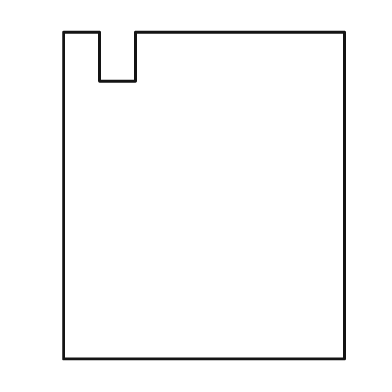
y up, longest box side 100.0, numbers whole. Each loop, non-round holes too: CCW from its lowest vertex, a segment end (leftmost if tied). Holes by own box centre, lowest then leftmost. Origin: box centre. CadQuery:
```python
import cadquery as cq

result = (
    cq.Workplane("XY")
    .moveTo(-43.0, -50.0)
    .lineTo(43.0, -50.0)
    .lineTo(43.0, 50.0)
    .lineTo(-21.0, 50.0)
    .lineTo(-21.0, 35.0)
    .lineTo(-32.0, 35.0)
    .lineTo(-32.0, 50.0)
    .lineTo(-43.0, 50.0)
    .close()
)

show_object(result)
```